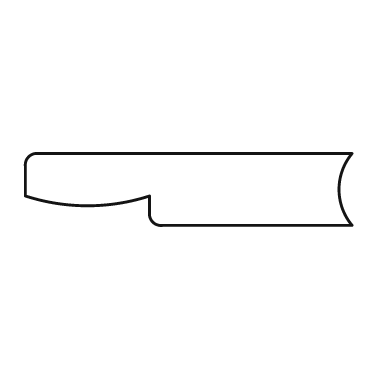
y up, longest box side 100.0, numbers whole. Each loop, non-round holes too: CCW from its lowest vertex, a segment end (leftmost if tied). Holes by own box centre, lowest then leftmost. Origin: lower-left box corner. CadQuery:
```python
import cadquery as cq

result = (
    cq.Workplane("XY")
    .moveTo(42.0, 0.0)
    .lineTo(100.0, 0.0)
    .threePointArc((96.0, 11.0), (100.0, 22.0))
    .lineTo(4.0, 22.0)
    .threePointArc((1.0, 21.0), (0.0, 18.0))
    .lineTo(0.0, 9.0)
    .threePointArc((19.0, 6.0), (38.0, 9.0))
    .lineTo(38.0, 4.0)
    .threePointArc((39.0, 1.0), (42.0, 0.0))
    .close()
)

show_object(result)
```